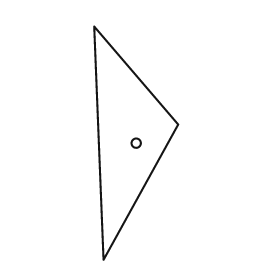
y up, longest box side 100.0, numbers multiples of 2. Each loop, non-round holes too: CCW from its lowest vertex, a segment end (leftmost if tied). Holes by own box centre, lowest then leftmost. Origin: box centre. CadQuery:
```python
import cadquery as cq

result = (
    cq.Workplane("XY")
    .moveTo(-14.0, -50.0)
    .lineTo(18.0, 8.0)
    .lineTo(-18.0, 50.0)
    .close()
    .moveTo(0.0, 0.0)
    .circle(2.0)
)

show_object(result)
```